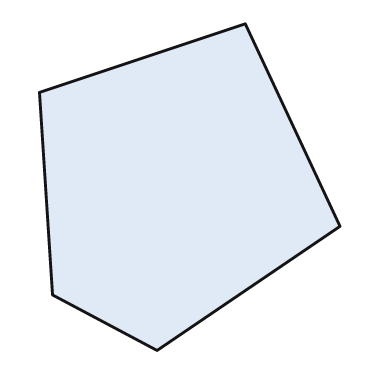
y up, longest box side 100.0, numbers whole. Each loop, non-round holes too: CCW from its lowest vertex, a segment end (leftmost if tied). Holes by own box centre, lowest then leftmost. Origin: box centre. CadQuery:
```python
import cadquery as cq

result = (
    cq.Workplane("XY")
    .moveTo(-10.0, -50.0)
    .lineTo(46.0, -12.0)
    .lineTo(17.0, 50.0)
    .lineTo(-46.0, 29.0)
    .lineTo(-42.0, -33.0)
    .close()
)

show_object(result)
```